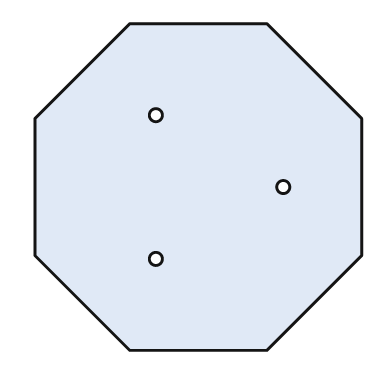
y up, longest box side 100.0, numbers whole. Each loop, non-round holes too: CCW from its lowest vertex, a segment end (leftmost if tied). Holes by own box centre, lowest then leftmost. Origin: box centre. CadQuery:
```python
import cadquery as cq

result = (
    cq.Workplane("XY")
    .moveTo(-21.0, -50.0)
    .lineTo(21.0, -50.0)
    .lineTo(50.0, -21.0)
    .lineTo(50.0, 21.0)
    .lineTo(21.0, 50.0)
    .lineTo(-21.0, 50.0)
    .lineTo(-50.0, 21.0)
    .lineTo(-50.0, -21.0)
    .close()
    .moveTo(-13.0, -22.0)
    .circle(2.0)
    .moveTo(26.0, 0.0)
    .circle(2.0)
    .moveTo(-13.0, 22.0)
    .circle(2.0)
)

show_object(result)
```